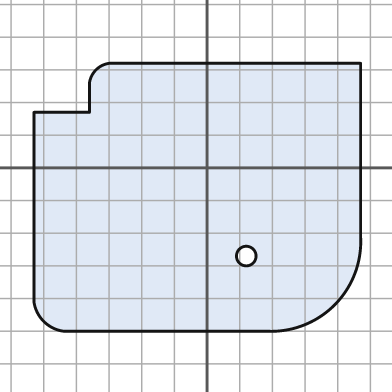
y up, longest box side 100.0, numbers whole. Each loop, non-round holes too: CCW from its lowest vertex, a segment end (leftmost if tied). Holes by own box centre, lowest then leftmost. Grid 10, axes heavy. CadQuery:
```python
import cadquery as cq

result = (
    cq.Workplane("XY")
    .moveTo(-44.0, -50.0)
    .lineTo(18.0, -50.0)
    .threePointArc((39.0, -42.0), (47.0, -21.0))
    .lineTo(47.0, 32.0)
    .lineTo(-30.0, 32.0)
    .threePointArc((-34.0, 30.0), (-36.0, 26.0))
    .lineTo(-36.0, 17.0)
    .lineTo(-53.0, 17.0)
    .lineTo(-53.0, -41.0)
    .threePointArc((-50.0, -47.0), (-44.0, -50.0))
    .close()
    .moveTo(12.0, -27.0)
    .circle(3.0)
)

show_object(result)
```